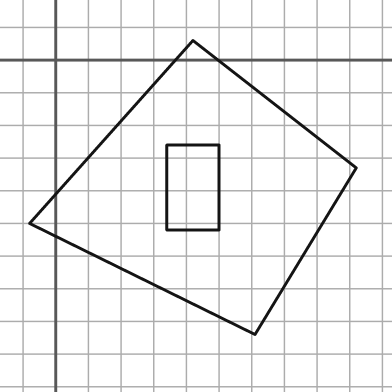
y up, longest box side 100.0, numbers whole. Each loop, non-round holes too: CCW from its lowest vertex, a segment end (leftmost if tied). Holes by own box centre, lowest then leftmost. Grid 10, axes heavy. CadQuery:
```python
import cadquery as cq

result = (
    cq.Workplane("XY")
    .moveTo(61.0, -84.0)
    .lineTo(92.0, -33.0)
    .lineTo(42.0, 6.0)
    .lineTo(-8.0, -50.0)
    .close()
    .moveTo(34.0, -52.0)
    .lineTo(50.0, -52.0)
    .lineTo(50.0, -26.0)
    .lineTo(34.0, -26.0)
    .close()
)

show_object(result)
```